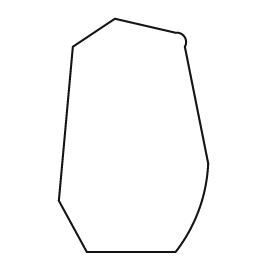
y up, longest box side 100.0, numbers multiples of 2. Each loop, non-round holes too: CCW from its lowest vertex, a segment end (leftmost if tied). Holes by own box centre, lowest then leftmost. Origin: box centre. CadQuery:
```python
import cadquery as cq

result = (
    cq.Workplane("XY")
    .moveTo(-20.0, -50.0)
    .lineTo(18.0, -50.0)
    .threePointArc((28.0, -32.0), (32.0, -12.0))
    .lineTo(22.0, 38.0)
    .threePointArc((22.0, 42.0), (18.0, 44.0))
    .lineTo(-8.0, 50.0)
    .lineTo(-26.0, 38.0)
    .lineTo(-32.0, -28.0)
    .close()
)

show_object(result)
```